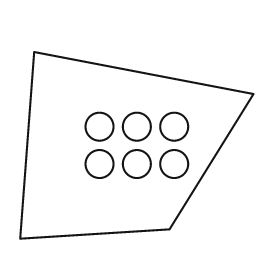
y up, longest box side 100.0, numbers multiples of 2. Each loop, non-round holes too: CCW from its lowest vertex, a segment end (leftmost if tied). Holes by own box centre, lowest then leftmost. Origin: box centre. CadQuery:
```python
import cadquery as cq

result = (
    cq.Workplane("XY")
    .moveTo(-50.0, -40.0)
    .lineTo(14.0, -36.0)
    .lineTo(50.0, 22.0)
    .lineTo(-44.0, 40.0)
    .close()
    .moveTo(-16.0, -8.0)
    .circle(6.0)
    .moveTo(0.0, -8.0)
    .circle(6.0)
    .moveTo(16.0, -8.0)
    .circle(6.0)
    .moveTo(-16.0, 8.0)
    .circle(6.0)
    .moveTo(0.0, 8.0)
    .circle(6.0)
    .moveTo(16.0, 8.0)
    .circle(6.0)
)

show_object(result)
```